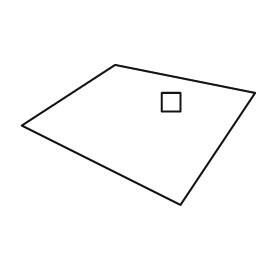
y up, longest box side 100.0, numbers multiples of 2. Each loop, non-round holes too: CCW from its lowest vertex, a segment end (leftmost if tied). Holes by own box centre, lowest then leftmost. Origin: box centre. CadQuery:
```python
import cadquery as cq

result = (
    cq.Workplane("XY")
    .moveTo(18.0, -30.0)
    .lineTo(50.0, 18.0)
    .lineTo(-10.0, 30.0)
    .lineTo(-50.0, 4.0)
    .close()
    .moveTo(10.0, 10.0)
    .lineTo(18.0, 10.0)
    .lineTo(18.0, 18.0)
    .lineTo(10.0, 18.0)
    .close()
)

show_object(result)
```